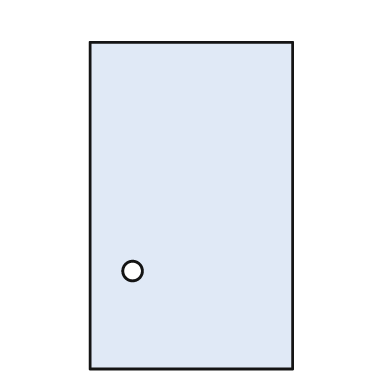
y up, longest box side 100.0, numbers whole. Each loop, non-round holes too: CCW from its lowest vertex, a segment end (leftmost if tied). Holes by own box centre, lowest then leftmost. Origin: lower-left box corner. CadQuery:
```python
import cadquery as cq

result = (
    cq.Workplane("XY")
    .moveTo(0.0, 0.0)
    .lineTo(62.0, 0.0)
    .lineTo(62.0, 100.0)
    .lineTo(0.0, 100.0)
    .close()
    .moveTo(13.0, 30.0)
    .circle(3.0)
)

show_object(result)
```